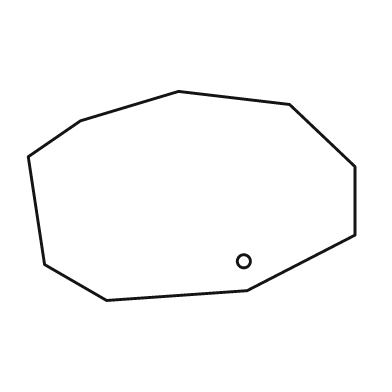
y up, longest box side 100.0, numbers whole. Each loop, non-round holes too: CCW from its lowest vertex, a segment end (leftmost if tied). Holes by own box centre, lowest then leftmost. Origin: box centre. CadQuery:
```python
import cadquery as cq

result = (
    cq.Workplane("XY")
    .moveTo(-26.0, -32.0)
    .lineTo(17.0, -29.0)
    .lineTo(50.0, -12.0)
    .lineTo(50.0, 9.0)
    .lineTo(30.0, 28.0)
    .lineTo(-4.0, 32.0)
    .lineTo(-34.0, 23.0)
    .lineTo(-50.0, 12.0)
    .lineTo(-45.0, -21.0)
    .close()
    .moveTo(16.0, -20.0)
    .circle(2.0)
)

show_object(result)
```